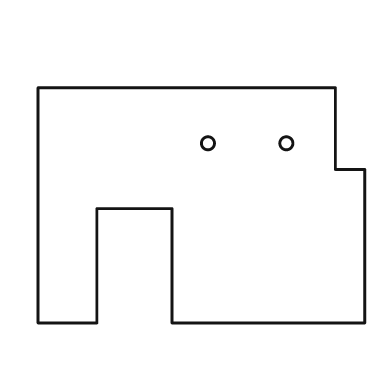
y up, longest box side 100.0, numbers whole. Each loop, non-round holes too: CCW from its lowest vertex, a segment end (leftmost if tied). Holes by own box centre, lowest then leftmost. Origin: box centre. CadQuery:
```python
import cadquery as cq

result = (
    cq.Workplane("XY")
    .moveTo(-50.0, -36.0)
    .lineTo(-32.0, -36.0)
    .lineTo(-32.0, -1.0)
    .lineTo(-9.0, -1.0)
    .lineTo(-9.0, -36.0)
    .lineTo(50.0, -36.0)
    .lineTo(50.0, 11.0)
    .lineTo(41.0, 11.0)
    .lineTo(41.0, 36.0)
    .lineTo(-50.0, 36.0)
    .close()
    .moveTo(2.0, 19.0)
    .circle(2.0)
    .moveTo(26.0, 19.0)
    .circle(2.0)
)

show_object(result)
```